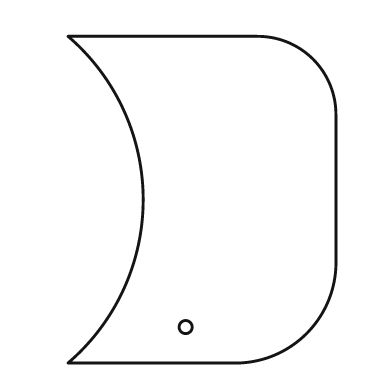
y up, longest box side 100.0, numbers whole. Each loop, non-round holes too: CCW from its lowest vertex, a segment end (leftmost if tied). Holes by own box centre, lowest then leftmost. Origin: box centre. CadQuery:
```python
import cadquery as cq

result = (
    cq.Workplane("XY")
    .moveTo(-41.0, -50.0)
    .lineTo(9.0, -50.0)
    .threePointArc((32.0, -41.0), (41.0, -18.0))
    .lineTo(41.0, 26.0)
    .threePointArc((34.0, 43.0), (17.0, 50.0))
    .lineTo(-41.0, 50.0)
    .threePointArc((-18.0, 0.0), (-41.0, -50.0))
    .close()
    .moveTo(-5.0, -39.0)
    .circle(2.0)
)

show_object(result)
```